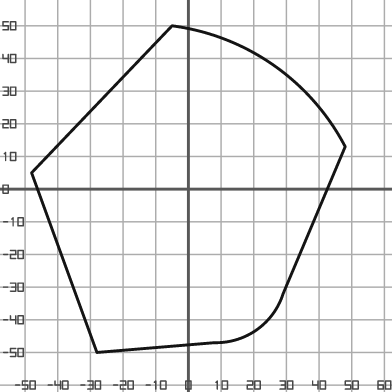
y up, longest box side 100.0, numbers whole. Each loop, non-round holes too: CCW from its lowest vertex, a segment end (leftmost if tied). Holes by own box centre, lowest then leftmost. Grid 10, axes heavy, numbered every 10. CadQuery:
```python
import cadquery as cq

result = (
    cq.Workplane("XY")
    .moveTo(-28.0, -50.0)
    .lineTo(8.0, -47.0)
    .threePointArc((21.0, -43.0), (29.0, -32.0))
    .lineTo(48.0, 13.0)
    .threePointArc((26.0, 38.0), (-5.0, 50.0))
    .lineTo(-48.0, 5.0)
    .close()
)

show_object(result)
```